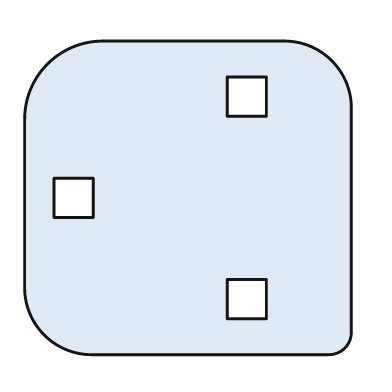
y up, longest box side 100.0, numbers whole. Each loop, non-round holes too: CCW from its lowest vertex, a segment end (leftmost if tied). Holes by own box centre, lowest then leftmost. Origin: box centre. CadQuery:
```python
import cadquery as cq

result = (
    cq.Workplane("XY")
    .moveTo(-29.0, -48.0)
    .lineTo(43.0, -48.0)
    .threePointArc((48.0, -46.0), (50.0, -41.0))
    .lineTo(50.0, 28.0)
    .threePointArc((44.0, 42.0), (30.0, 48.0))
    .lineTo(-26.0, 48.0)
    .threePointArc((-43.0, 41.0), (-50.0, 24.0))
    .lineTo(-50.0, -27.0)
    .threePointArc((-44.0, -42.0), (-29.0, -48.0))
    .close()
    .moveTo(12.0, -37.0)
    .lineTo(24.0, -37.0)
    .lineTo(24.0, -25.0)
    .lineTo(12.0, -25.0)
    .close()
    .moveTo(-41.0, -6.0)
    .lineTo(-29.0, -6.0)
    .lineTo(-29.0, 6.0)
    .lineTo(-41.0, 6.0)
    .close()
    .moveTo(12.0, 25.0)
    .lineTo(24.0, 25.0)
    .lineTo(24.0, 37.0)
    .lineTo(12.0, 37.0)
    .close()
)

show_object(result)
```